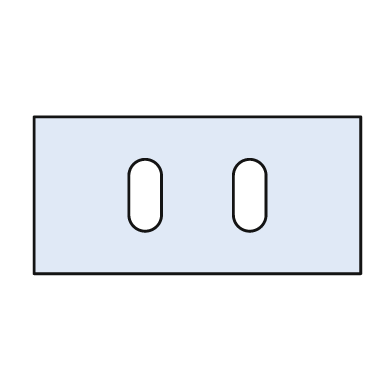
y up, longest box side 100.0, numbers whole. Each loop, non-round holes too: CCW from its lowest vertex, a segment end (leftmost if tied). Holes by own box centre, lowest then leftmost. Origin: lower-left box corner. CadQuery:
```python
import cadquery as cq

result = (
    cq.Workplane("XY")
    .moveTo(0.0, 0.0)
    .lineTo(100.0, 0.0)
    .lineTo(100.0, 48.0)
    .lineTo(0.0, 48.0)
    .close()
    .moveTo(29.0, 18.0)
    .threePointArc((34.0, 13.0), (39.0, 18.0))
    .lineTo(39.0, 30.0)
    .threePointArc((34.0, 35.0), (29.0, 30.0))
    .close()
    .moveTo(61.0, 18.0)
    .threePointArc((66.0, 13.0), (71.0, 18.0))
    .lineTo(71.0, 30.0)
    .threePointArc((66.0, 35.0), (61.0, 30.0))
    .close()
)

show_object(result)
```